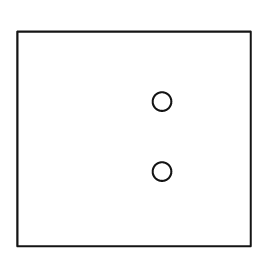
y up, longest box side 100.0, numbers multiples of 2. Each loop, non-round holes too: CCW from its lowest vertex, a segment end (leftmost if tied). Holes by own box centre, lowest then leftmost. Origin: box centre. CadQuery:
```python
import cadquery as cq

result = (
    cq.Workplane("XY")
    .moveTo(-50.0, -46.0)
    .lineTo(50.0, -46.0)
    .lineTo(50.0, 46.0)
    .lineTo(-50.0, 46.0)
    .close()
    .moveTo(12.0, -14.0)
    .circle(4.0)
    .moveTo(12.0, 16.0)
    .circle(4.0)
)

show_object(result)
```